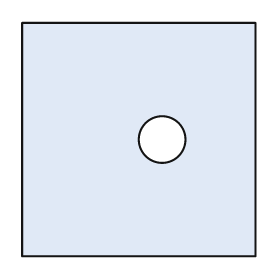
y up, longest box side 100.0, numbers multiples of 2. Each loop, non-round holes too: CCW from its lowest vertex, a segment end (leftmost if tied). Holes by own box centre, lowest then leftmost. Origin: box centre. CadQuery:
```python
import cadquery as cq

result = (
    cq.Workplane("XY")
    .moveTo(-50.0, -50.0)
    .lineTo(50.0, -50.0)
    .lineTo(50.0, 50.0)
    .lineTo(-50.0, 50.0)
    .close()
    .moveTo(10.0, 0.0)
    .circle(10.0)
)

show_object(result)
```